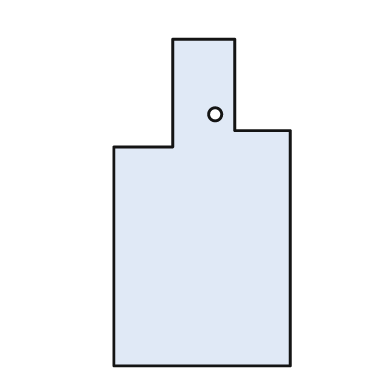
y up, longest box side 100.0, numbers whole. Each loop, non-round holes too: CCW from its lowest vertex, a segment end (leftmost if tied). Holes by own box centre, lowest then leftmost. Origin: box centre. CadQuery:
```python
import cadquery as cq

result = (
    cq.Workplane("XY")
    .moveTo(-27.0, -50.0)
    .lineTo(27.0, -50.0)
    .lineTo(27.0, 22.0)
    .lineTo(10.0, 22.0)
    .lineTo(10.0, 50.0)
    .lineTo(-9.0, 50.0)
    .lineTo(-9.0, 17.0)
    .lineTo(-27.0, 17.0)
    .close()
    .moveTo(4.0, 27.0)
    .circle(2.0)
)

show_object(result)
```